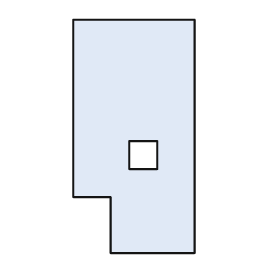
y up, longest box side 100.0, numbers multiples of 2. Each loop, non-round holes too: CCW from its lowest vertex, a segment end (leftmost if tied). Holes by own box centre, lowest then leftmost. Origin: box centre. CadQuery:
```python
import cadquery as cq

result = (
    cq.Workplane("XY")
    .moveTo(-10.0, -50.0)
    .lineTo(26.0, -50.0)
    .lineTo(26.0, 50.0)
    .lineTo(-26.0, 50.0)
    .lineTo(-26.0, -26.0)
    .lineTo(-10.0, -26.0)
    .close()
    .moveTo(-2.0, -14.0)
    .lineTo(10.0, -14.0)
    .lineTo(10.0, -2.0)
    .lineTo(-2.0, -2.0)
    .close()
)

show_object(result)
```